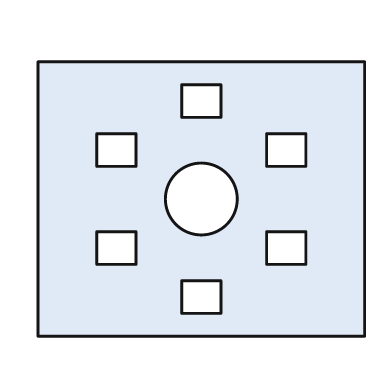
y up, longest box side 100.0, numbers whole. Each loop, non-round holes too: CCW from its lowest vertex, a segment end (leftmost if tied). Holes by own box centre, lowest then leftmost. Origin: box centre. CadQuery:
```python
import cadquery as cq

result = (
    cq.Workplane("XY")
    .moveTo(-50.0, -42.0)
    .lineTo(50.0, -42.0)
    .lineTo(50.0, 42.0)
    .lineTo(-50.0, 42.0)
    .close()
    .moveTo(-6.0, -35.0)
    .lineTo(6.0, -35.0)
    .lineTo(6.0, -25.0)
    .lineTo(-6.0, -25.0)
    .close()
    .moveTo(-32.0, -20.0)
    .lineTo(-20.0, -20.0)
    .lineTo(-20.0, -10.0)
    .lineTo(-32.0, -10.0)
    .close()
    .moveTo(20.0, -20.0)
    .lineTo(32.0, -20.0)
    .lineTo(32.0, -10.0)
    .lineTo(20.0, -10.0)
    .close()
    .moveTo(0.0, 0.0)
    .circle(11.0)
    .moveTo(-32.0, 10.0)
    .lineTo(-20.0, 10.0)
    .lineTo(-20.0, 20.0)
    .lineTo(-32.0, 20.0)
    .close()
    .moveTo(20.0, 10.0)
    .lineTo(32.0, 10.0)
    .lineTo(32.0, 20.0)
    .lineTo(20.0, 20.0)
    .close()
    .moveTo(-6.0, 25.0)
    .lineTo(6.0, 25.0)
    .lineTo(6.0, 35.0)
    .lineTo(-6.0, 35.0)
    .close()
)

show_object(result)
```